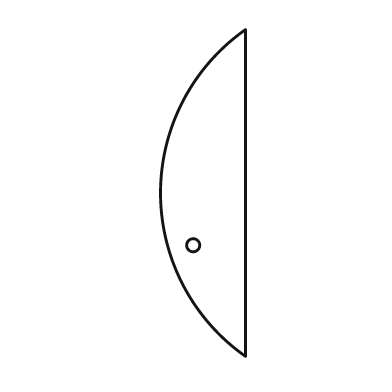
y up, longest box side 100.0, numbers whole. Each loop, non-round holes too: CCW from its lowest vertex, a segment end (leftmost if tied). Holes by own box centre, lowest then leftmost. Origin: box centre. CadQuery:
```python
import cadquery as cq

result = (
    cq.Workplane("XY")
    .moveTo(13.0, -50.0)
    .lineTo(13.0, 50.0)
    .threePointArc((-13.0, 0.0), (13.0, -50.0))
    .close()
    .moveTo(-3.0, -16.0)
    .circle(2.0)
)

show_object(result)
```